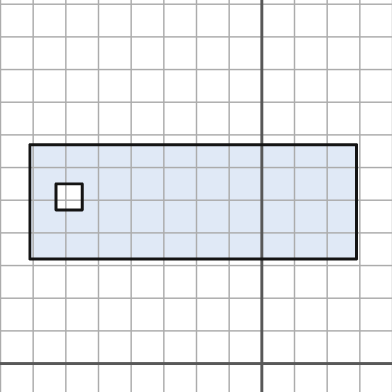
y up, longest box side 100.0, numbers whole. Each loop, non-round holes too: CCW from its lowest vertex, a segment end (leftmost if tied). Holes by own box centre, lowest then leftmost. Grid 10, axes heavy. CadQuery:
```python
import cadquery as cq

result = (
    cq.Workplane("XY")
    .moveTo(-71.0, 32.0)
    .lineTo(29.0, 32.0)
    .lineTo(29.0, 67.0)
    .lineTo(-71.0, 67.0)
    .close()
    .moveTo(-63.0, 47.0)
    .lineTo(-55.0, 47.0)
    .lineTo(-55.0, 55.0)
    .lineTo(-63.0, 55.0)
    .close()
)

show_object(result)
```